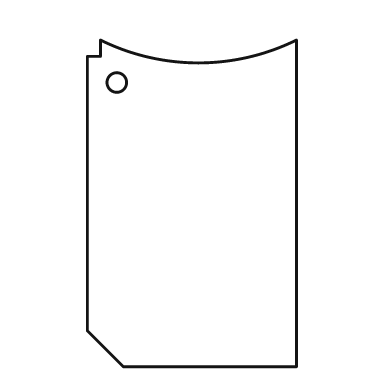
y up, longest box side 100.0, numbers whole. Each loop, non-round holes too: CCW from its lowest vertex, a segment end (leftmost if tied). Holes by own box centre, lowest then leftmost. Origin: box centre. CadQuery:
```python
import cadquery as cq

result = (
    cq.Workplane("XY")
    .moveTo(-21.0, -50.0)
    .lineTo(32.0, -50.0)
    .lineTo(32.0, 50.0)
    .threePointArc((2.0, 43.0), (-28.0, 50.0))
    .lineTo(-28.0, 45.0)
    .lineTo(-32.0, 45.0)
    .lineTo(-32.0, -39.0)
    .close()
    .moveTo(-23.0, 37.0)
    .circle(3.0)
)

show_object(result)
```